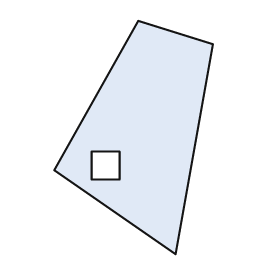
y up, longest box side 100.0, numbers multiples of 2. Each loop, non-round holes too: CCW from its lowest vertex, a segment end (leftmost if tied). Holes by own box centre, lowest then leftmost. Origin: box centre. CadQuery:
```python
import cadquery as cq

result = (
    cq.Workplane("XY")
    .moveTo(18.0, -50.0)
    .lineTo(34.0, 40.0)
    .lineTo(2.0, 50.0)
    .lineTo(-34.0, -14.0)
    .close()
    .moveTo(-18.0, -18.0)
    .lineTo(-6.0, -18.0)
    .lineTo(-6.0, -6.0)
    .lineTo(-18.0, -6.0)
    .close()
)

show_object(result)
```